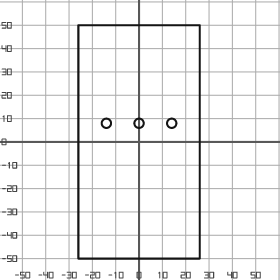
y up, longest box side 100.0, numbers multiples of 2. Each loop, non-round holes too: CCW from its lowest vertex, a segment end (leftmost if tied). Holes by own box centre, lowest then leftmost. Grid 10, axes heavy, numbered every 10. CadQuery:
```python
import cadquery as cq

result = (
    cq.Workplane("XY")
    .moveTo(-26.0, -50.0)
    .lineTo(26.0, -50.0)
    .lineTo(26.0, 50.0)
    .lineTo(-26.0, 50.0)
    .close()
    .moveTo(-14.0, 8.0)
    .circle(2.0)
    .moveTo(0.0, 8.0)
    .circle(2.0)
    .moveTo(14.0, 8.0)
    .circle(2.0)
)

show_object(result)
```